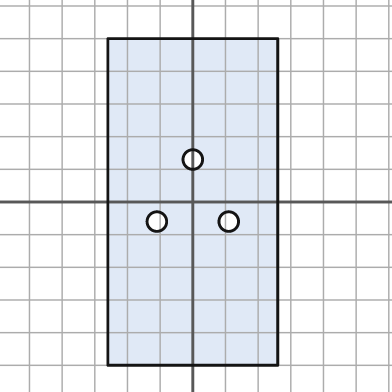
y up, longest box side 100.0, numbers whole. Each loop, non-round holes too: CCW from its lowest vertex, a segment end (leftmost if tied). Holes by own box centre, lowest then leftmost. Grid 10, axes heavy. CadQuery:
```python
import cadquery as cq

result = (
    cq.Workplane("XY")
    .moveTo(-26.0, -50.0)
    .lineTo(26.0, -50.0)
    .lineTo(26.0, 50.0)
    .lineTo(-26.0, 50.0)
    .close()
    .moveTo(-11.0, -6.0)
    .circle(3.0)
    .moveTo(11.0, -6.0)
    .circle(3.0)
    .moveTo(0.0, 13.0)
    .circle(3.0)
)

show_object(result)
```